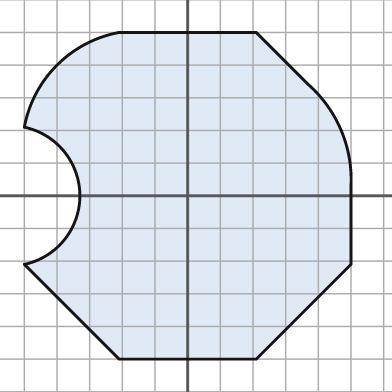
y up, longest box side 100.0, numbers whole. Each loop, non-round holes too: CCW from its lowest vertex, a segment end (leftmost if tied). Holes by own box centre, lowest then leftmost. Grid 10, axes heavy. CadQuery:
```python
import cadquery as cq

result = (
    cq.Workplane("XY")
    .moveTo(-21.0, -50.0)
    .lineTo(21.0, -50.0)
    .lineTo(50.0, -21.0)
    .lineTo(50.0, 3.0)
    .threePointArc((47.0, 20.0), (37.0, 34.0))
    .lineTo(21.0, 50.0)
    .lineTo(-21.0, 50.0)
    .threePointArc((-40.0, 40.0), (-50.0, 21.0))
    .threePointArc((-33.0, 0.0), (-50.0, -21.0))
    .close()
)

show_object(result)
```